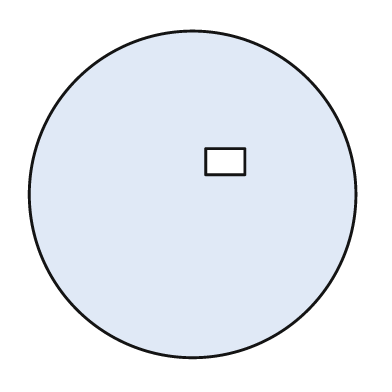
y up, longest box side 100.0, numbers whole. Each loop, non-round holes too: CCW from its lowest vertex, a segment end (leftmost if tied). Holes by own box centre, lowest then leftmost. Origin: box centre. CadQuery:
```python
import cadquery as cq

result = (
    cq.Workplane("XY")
    .moveTo(0.0, 0.0)
    .circle(50.0)
    .moveTo(4.0, 6.0)
    .lineTo(16.0, 6.0)
    .lineTo(16.0, 14.0)
    .lineTo(4.0, 14.0)
    .close()
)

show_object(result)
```